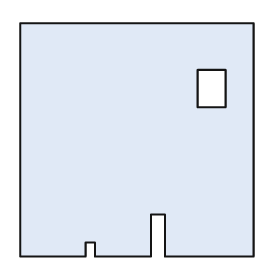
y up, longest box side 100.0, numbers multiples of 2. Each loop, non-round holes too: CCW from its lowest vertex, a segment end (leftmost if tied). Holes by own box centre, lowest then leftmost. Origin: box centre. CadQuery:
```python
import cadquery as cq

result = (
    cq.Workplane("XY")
    .moveTo(-50.0, -50.0)
    .lineTo(-22.0, -50.0)
    .lineTo(-22.0, -44.0)
    .lineTo(-18.0, -44.0)
    .lineTo(-18.0, -50.0)
    .lineTo(6.0, -50.0)
    .lineTo(6.0, -32.0)
    .lineTo(12.0, -32.0)
    .lineTo(12.0, -50.0)
    .lineTo(50.0, -50.0)
    .lineTo(50.0, 50.0)
    .lineTo(-50.0, 50.0)
    .close()
    .moveTo(26.0, 14.0)
    .lineTo(38.0, 14.0)
    .lineTo(38.0, 30.0)
    .lineTo(26.0, 30.0)
    .close()
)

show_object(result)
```